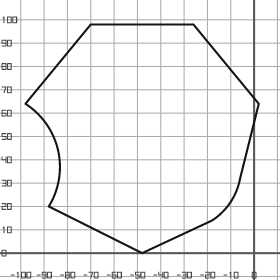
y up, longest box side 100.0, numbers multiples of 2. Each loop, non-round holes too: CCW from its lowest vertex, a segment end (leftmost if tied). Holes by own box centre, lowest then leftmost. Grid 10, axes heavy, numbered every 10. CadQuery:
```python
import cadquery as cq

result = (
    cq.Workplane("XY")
    .moveTo(-48.0, 0.0)
    .lineTo(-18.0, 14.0)
    .threePointArc((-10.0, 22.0), (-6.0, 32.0))
    .lineTo(2.0, 64.0)
    .lineTo(-26.0, 98.0)
    .lineTo(-70.0, 98.0)
    .lineTo(-98.0, 64.0)
    .threePointArc((-84.0, 44.0), (-88.0, 20.0))
    .close()
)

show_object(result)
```